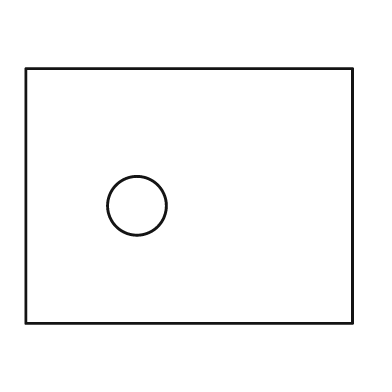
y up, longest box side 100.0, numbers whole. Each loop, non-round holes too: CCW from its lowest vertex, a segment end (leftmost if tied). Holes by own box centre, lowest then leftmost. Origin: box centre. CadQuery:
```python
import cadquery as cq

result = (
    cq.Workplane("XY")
    .moveTo(-50.0, -39.0)
    .lineTo(50.0, -39.0)
    .lineTo(50.0, 39.0)
    .lineTo(-50.0, 39.0)
    .close()
    .moveTo(-16.0, -3.0)
    .circle(9.0)
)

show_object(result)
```